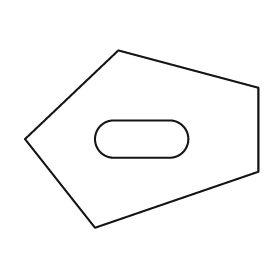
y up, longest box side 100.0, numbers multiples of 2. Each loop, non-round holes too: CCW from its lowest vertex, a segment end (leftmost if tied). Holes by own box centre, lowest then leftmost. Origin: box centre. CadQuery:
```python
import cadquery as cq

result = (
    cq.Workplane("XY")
    .moveTo(-20.0, -38.0)
    .lineTo(50.0, -14.0)
    .lineTo(50.0, 22.0)
    .lineTo(-10.0, 38.0)
    .lineTo(-50.0, 0.0)
    .close()
    .moveTo(-12.0, -8.0)
    .lineTo(12.0, -8.0)
    .threePointArc((20.0, 0.0), (12.0, 8.0))
    .lineTo(-12.0, 8.0)
    .threePointArc((-20.0, 0.0), (-12.0, -8.0))
    .close()
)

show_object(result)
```